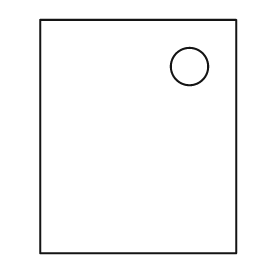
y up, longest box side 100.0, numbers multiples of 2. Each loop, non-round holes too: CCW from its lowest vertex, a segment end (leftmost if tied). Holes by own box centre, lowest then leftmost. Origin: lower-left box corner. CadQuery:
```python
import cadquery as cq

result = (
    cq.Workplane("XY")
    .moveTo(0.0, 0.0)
    .lineTo(84.0, 0.0)
    .lineTo(84.0, 100.0)
    .lineTo(0.0, 100.0)
    .close()
    .moveTo(64.0, 80.0)
    .circle(8.0)
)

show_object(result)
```